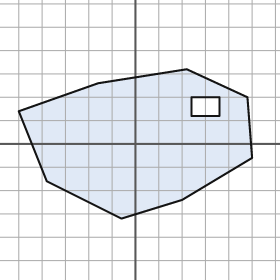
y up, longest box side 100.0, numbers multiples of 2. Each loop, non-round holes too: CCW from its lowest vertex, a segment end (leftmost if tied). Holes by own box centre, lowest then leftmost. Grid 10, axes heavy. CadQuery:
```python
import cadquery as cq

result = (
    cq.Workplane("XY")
    .moveTo(-6.0, -32.0)
    .lineTo(20.0, -24.0)
    .lineTo(50.0, -6.0)
    .lineTo(48.0, 20.0)
    .lineTo(22.0, 32.0)
    .lineTo(-16.0, 26.0)
    .lineTo(-50.0, 14.0)
    .lineTo(-38.0, -16.0)
    .close()
    .moveTo(24.0, 12.0)
    .lineTo(36.0, 12.0)
    .lineTo(36.0, 20.0)
    .lineTo(24.0, 20.0)
    .close()
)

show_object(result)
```